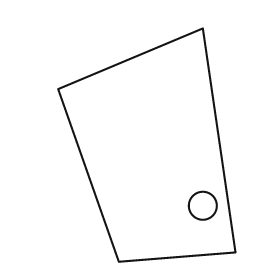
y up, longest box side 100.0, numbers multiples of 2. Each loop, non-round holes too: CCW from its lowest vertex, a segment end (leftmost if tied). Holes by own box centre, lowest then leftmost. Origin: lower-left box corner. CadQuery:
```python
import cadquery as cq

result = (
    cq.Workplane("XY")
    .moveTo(26.0, 0.0)
    .lineTo(76.0, 4.0)
    .lineTo(62.0, 100.0)
    .lineTo(0.0, 74.0)
    .close()
    .moveTo(62.0, 24.0)
    .circle(6.0)
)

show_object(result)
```